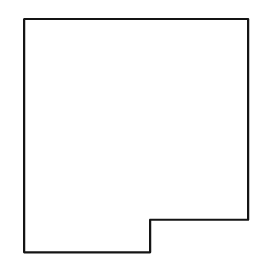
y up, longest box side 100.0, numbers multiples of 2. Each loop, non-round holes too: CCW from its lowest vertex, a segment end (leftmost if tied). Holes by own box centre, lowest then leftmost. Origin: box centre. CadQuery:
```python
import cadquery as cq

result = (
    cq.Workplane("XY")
    .moveTo(-48.0, -50.0)
    .lineTo(6.0, -50.0)
    .lineTo(6.0, -36.0)
    .lineTo(48.0, -36.0)
    .lineTo(48.0, 50.0)
    .lineTo(-48.0, 50.0)
    .close()
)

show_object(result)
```